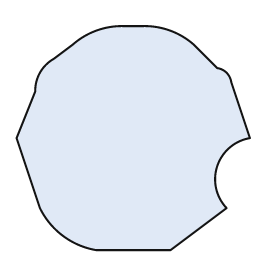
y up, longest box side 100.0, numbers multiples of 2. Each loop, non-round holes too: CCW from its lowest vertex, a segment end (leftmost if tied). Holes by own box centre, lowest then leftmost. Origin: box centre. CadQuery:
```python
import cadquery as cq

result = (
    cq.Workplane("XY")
    .moveTo(-16.0, -48.0)
    .lineTo(16.0, -48.0)
    .lineTo(40.0, -30.0)
    .threePointArc((36.0, -12.0), (50.0, 0.0))
    .lineTo(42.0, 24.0)
    .threePointArc((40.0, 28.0), (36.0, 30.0))
    .lineTo(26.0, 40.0)
    .threePointArc((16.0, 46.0), (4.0, 48.0))
    .lineTo(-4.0, 48.0)
    .threePointArc((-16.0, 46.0), (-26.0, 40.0))
    .lineTo(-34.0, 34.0)
    .threePointArc((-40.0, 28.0), (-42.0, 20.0))
    .lineTo(-50.0, 0.0)
    .lineTo(-40.0, -30.0)
    .threePointArc((-30.0, -42.0), (-16.0, -48.0))
    .close()
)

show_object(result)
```